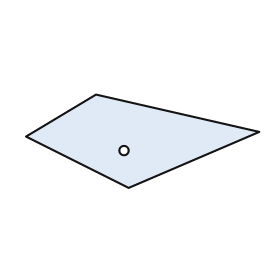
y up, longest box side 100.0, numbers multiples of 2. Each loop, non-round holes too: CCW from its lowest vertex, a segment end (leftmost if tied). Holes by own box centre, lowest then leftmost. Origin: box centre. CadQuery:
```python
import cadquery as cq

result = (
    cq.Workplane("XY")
    .moveTo(-6.0, -20.0)
    .lineTo(50.0, 4.0)
    .lineTo(-20.0, 20.0)
    .lineTo(-50.0, 2.0)
    .close()
    .moveTo(-8.0, -4.0)
    .circle(2.0)
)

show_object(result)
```